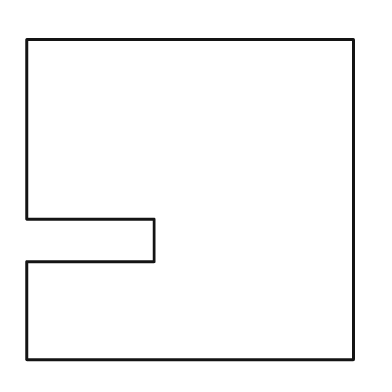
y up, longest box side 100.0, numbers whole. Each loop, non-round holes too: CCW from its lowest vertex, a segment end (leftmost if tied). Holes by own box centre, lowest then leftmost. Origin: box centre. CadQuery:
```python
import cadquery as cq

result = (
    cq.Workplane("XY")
    .moveTo(-50.0, -49.0)
    .lineTo(50.0, -49.0)
    .lineTo(50.0, 49.0)
    .lineTo(-50.0, 49.0)
    .lineTo(-50.0, -6.0)
    .lineTo(-11.0, -6.0)
    .lineTo(-11.0, -19.0)
    .lineTo(-50.0, -19.0)
    .close()
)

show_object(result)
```